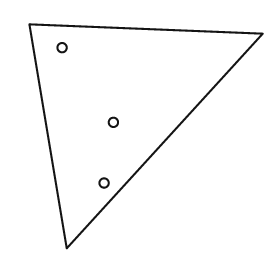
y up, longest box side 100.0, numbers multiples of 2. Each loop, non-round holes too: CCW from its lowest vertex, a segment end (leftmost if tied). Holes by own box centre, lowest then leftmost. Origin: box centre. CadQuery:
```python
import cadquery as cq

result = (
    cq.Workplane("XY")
    .moveTo(-34.0, -48.0)
    .lineTo(50.0, 44.0)
    .lineTo(-50.0, 48.0)
    .close()
    .moveTo(-18.0, -20.0)
    .circle(2.0)
    .moveTo(-14.0, 6.0)
    .circle(2.0)
    .moveTo(-36.0, 38.0)
    .circle(2.0)
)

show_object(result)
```